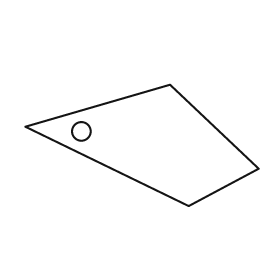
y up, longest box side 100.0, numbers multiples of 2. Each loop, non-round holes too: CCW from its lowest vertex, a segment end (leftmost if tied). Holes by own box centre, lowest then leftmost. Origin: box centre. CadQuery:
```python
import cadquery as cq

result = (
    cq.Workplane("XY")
    .moveTo(20.0, -26.0)
    .lineTo(50.0, -10.0)
    .lineTo(12.0, 26.0)
    .lineTo(-50.0, 8.0)
    .close()
    .moveTo(-26.0, 6.0)
    .circle(4.0)
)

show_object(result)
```